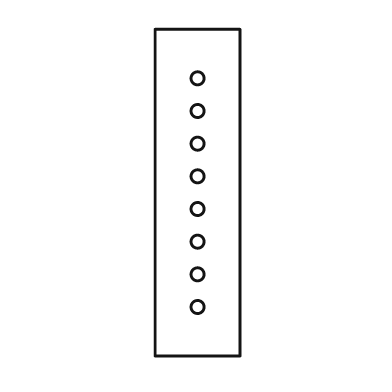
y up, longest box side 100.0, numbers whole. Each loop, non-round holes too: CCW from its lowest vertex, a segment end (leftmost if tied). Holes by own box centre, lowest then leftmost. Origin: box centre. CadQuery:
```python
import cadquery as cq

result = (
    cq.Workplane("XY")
    .moveTo(-13.0, -50.0)
    .lineTo(13.0, -50.0)
    .lineTo(13.0, 50.0)
    .lineTo(-13.0, 50.0)
    .close()
    .moveTo(0.0, -35.0)
    .circle(2.0)
    .moveTo(0.0, -25.0)
    .circle(2.0)
    .moveTo(0.0, -15.0)
    .circle(2.0)
    .moveTo(0.0, -5.0)
    .circle(2.0)
    .moveTo(0.0, 5.0)
    .circle(2.0)
    .moveTo(0.0, 15.0)
    .circle(2.0)
    .moveTo(0.0, 25.0)
    .circle(2.0)
    .moveTo(0.0, 35.0)
    .circle(2.0)
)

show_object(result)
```